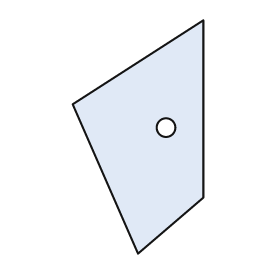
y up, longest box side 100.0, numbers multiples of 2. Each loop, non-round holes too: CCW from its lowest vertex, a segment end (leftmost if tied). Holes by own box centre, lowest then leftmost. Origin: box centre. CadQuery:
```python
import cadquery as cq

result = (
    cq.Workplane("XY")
    .moveTo(0.0, -50.0)
    .lineTo(28.0, -26.0)
    .lineTo(28.0, 50.0)
    .lineTo(-28.0, 14.0)
    .close()
    .moveTo(12.0, 4.0)
    .circle(4.0)
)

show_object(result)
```